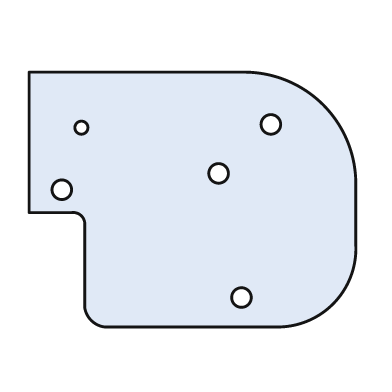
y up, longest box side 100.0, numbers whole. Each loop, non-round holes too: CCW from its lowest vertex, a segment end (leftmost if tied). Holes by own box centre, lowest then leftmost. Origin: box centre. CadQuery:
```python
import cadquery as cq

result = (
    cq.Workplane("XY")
    .moveTo(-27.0, -39.0)
    .lineTo(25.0, -39.0)
    .threePointArc((43.0, -32.0), (50.0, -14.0))
    .lineTo(50.0, 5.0)
    .threePointArc((40.0, 29.0), (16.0, 39.0))
    .lineTo(-50.0, 39.0)
    .lineTo(-50.0, -4.0)
    .lineTo(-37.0, -4.0)
    .threePointArc((-34.0, -5.0), (-33.0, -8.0))
    .lineTo(-33.0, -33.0)
    .threePointArc((-31.0, -37.0), (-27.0, -39.0))
    .close()
    .moveTo(15.0, -30.0)
    .circle(3.0)
    .moveTo(-40.0, 3.0)
    .circle(3.0)
    .moveTo(8.0, 8.0)
    .circle(3.0)
    .moveTo(-34.0, 22.0)
    .circle(2.0)
    .moveTo(24.0, 23.0)
    .circle(3.0)
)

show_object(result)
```